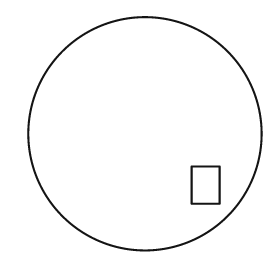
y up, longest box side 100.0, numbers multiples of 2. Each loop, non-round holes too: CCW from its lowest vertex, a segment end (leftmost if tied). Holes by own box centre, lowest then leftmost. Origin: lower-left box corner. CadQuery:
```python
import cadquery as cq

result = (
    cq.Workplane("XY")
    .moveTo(50.0, 50.0)
    .circle(50.0)
    .moveTo(70.0, 20.0)
    .lineTo(82.0, 20.0)
    .lineTo(82.0, 36.0)
    .lineTo(70.0, 36.0)
    .close()
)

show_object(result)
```